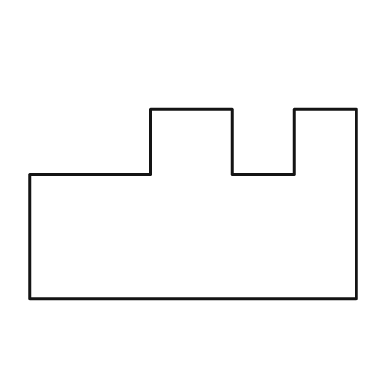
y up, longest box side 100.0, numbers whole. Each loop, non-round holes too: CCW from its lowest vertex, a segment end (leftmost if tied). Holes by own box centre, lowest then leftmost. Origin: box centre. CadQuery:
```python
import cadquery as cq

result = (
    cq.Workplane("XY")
    .moveTo(-50.0, -29.0)
    .lineTo(50.0, -29.0)
    .lineTo(50.0, 29.0)
    .lineTo(31.0, 29.0)
    .lineTo(31.0, 9.0)
    .lineTo(12.0, 9.0)
    .lineTo(12.0, 29.0)
    .lineTo(-13.0, 29.0)
    .lineTo(-13.0, 9.0)
    .lineTo(-50.0, 9.0)
    .close()
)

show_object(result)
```